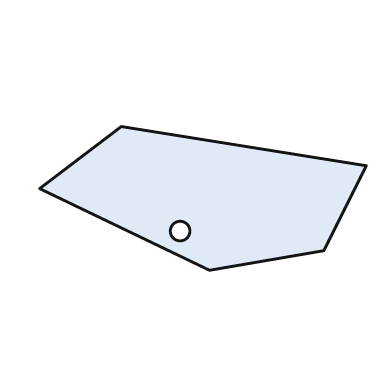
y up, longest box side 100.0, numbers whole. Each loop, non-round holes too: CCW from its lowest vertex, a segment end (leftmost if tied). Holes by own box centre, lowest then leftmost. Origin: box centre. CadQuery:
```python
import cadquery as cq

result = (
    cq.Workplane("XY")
    .moveTo(2.0, -22.0)
    .lineTo(37.0, -16.0)
    .lineTo(50.0, 10.0)
    .lineTo(-25.0, 22.0)
    .lineTo(-50.0, 3.0)
    .close()
    .moveTo(-7.0, -10.0)
    .circle(3.0)
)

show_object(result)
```